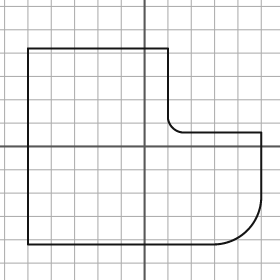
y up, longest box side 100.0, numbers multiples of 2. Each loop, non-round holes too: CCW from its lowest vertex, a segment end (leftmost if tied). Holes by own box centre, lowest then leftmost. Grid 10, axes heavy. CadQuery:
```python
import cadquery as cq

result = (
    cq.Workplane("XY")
    .moveTo(-50.0, -42.0)
    .lineTo(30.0, -42.0)
    .threePointArc((44.0, -36.0), (50.0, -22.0))
    .lineTo(50.0, 6.0)
    .lineTo(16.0, 6.0)
    .threePointArc((12.0, 8.0), (10.0, 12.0))
    .lineTo(10.0, 42.0)
    .lineTo(-50.0, 42.0)
    .close()
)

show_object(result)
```